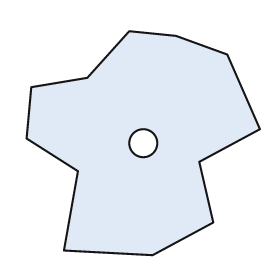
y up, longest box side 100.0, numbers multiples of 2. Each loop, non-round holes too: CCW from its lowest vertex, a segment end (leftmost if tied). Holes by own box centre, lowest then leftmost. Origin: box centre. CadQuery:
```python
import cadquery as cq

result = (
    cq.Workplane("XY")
    .moveTo(4.0, -48.0)
    .lineTo(30.0, -34.0)
    .lineTo(24.0, -8.0)
    .lineTo(50.0, 6.0)
    .lineTo(36.0, 38.0)
    .lineTo(14.0, 46.0)
    .lineTo(-6.0, 48.0)
    .lineTo(-24.0, 28.0)
    .lineTo(-48.0, 24.0)
    .lineTo(-50.0, 2.0)
    .lineTo(-28.0, -12.0)
    .lineTo(-34.0, -46.0)
    .close()
    .moveTo(0.0, 0.0)
    .circle(6.0)
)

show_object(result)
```